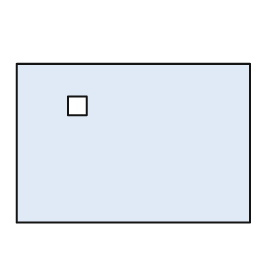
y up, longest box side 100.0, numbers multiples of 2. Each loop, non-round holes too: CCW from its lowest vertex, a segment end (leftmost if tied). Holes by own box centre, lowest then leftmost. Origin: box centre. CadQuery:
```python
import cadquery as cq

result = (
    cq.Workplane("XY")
    .moveTo(-50.0, -34.0)
    .lineTo(50.0, -34.0)
    .lineTo(50.0, 34.0)
    .lineTo(-50.0, 34.0)
    .close()
    .moveTo(-28.0, 12.0)
    .lineTo(-20.0, 12.0)
    .lineTo(-20.0, 20.0)
    .lineTo(-28.0, 20.0)
    .close()
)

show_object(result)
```